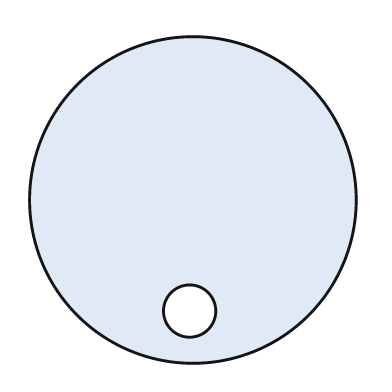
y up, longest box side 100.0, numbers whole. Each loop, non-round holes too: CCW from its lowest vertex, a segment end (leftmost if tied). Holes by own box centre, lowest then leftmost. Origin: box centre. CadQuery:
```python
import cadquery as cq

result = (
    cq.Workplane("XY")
    .moveTo(0.0, 0.0)
    .circle(50.0)
    .moveTo(-1.0, -34.0)
    .circle(8.0)
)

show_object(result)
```